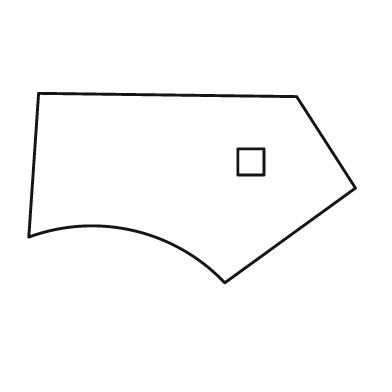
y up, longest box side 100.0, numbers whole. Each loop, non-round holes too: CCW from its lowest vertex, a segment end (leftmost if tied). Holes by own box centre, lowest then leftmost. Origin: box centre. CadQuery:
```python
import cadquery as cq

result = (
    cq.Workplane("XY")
    .moveTo(10.0, -29.0)
    .lineTo(50.0, 0.0)
    .lineTo(32.0, 28.0)
    .lineTo(-47.0, 29.0)
    .lineTo(-50.0, -15.0)
    .threePointArc((-18.0, -13.0), (10.0, -29.0))
    .close()
    .moveTo(14.0, 4.0)
    .lineTo(22.0, 4.0)
    .lineTo(22.0, 12.0)
    .lineTo(14.0, 12.0)
    .close()
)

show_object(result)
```